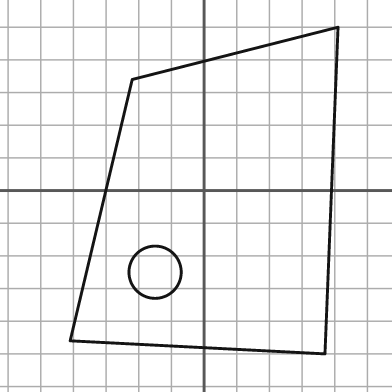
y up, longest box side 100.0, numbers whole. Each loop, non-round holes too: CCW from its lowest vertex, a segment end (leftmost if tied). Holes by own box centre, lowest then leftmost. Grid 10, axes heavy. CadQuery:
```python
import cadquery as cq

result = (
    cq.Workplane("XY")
    .moveTo(37.0, -50.0)
    .lineTo(41.0, 50.0)
    .lineTo(-22.0, 34.0)
    .lineTo(-41.0, -46.0)
    .close()
    .moveTo(-15.0, -25.0)
    .circle(8.0)
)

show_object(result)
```